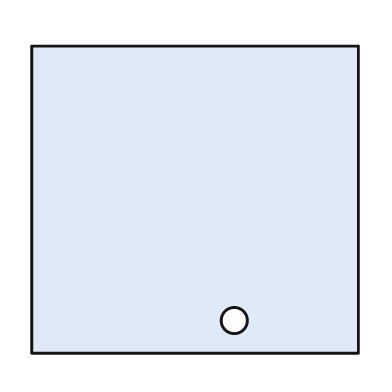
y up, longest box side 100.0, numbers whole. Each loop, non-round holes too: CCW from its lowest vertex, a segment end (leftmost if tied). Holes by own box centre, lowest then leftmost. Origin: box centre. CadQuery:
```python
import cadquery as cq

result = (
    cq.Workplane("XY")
    .moveTo(-50.0, -47.0)
    .lineTo(50.0, -47.0)
    .lineTo(50.0, 47.0)
    .lineTo(-50.0, 47.0)
    .close()
    .moveTo(12.0, -37.0)
    .circle(4.0)
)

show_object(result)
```